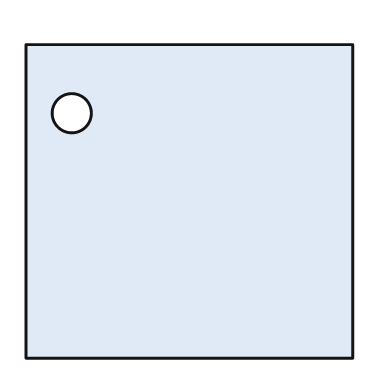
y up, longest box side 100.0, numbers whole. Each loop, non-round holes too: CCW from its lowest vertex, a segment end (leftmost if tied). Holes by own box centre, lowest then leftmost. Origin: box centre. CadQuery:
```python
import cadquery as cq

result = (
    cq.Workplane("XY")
    .moveTo(-50.0, -48.0)
    .lineTo(50.0, -48.0)
    .lineTo(50.0, 48.0)
    .lineTo(-50.0, 48.0)
    .close()
    .moveTo(-36.0, 27.0)
    .circle(6.0)
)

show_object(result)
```